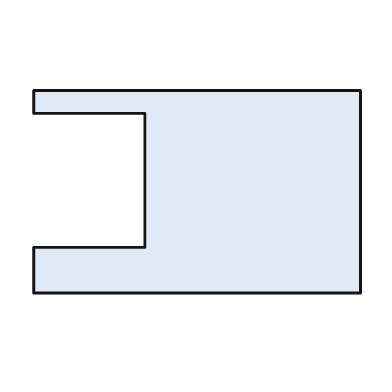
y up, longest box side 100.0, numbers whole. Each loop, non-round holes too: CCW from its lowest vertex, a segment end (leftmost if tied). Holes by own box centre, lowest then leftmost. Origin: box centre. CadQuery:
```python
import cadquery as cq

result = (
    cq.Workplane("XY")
    .moveTo(-50.0, -31.0)
    .lineTo(50.0, -31.0)
    .lineTo(50.0, 31.0)
    .lineTo(-50.0, 31.0)
    .lineTo(-50.0, 24.0)
    .lineTo(-16.0, 24.0)
    .lineTo(-16.0, -17.0)
    .lineTo(-50.0, -17.0)
    .close()
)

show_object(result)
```